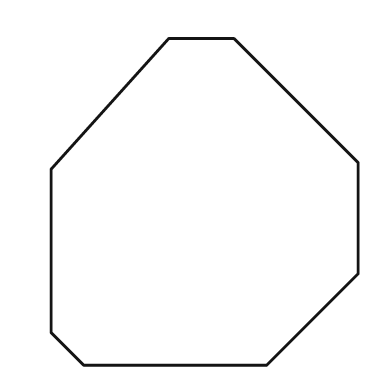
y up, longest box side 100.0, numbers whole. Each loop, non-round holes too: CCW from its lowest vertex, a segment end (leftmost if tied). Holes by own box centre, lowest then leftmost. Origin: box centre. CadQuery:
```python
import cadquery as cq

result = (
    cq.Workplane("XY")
    .moveTo(-37.0, -50.0)
    .lineTo(19.0, -50.0)
    .lineTo(47.0, -22.0)
    .lineTo(47.0, 12.0)
    .lineTo(9.0, 50.0)
    .lineTo(-11.0, 50.0)
    .lineTo(-47.0, 10.0)
    .lineTo(-47.0, -40.0)
    .close()
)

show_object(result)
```